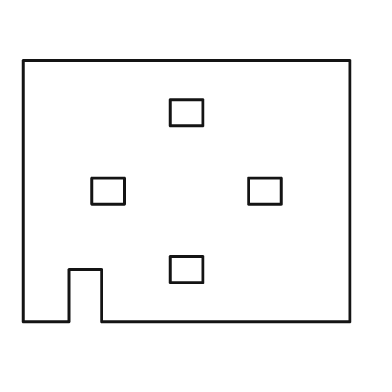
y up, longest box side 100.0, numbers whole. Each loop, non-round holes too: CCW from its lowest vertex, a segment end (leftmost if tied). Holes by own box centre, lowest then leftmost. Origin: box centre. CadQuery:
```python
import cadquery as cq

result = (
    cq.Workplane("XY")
    .moveTo(-50.0, -40.0)
    .lineTo(-36.0, -40.0)
    .lineTo(-36.0, -24.0)
    .lineTo(-26.0, -24.0)
    .lineTo(-26.0, -40.0)
    .lineTo(50.0, -40.0)
    .lineTo(50.0, 40.0)
    .lineTo(-50.0, 40.0)
    .close()
    .moveTo(-5.0, -28.0)
    .lineTo(5.0, -28.0)
    .lineTo(5.0, -20.0)
    .lineTo(-5.0, -20.0)
    .close()
    .moveTo(-29.0, -4.0)
    .lineTo(-19.0, -4.0)
    .lineTo(-19.0, 4.0)
    .lineTo(-29.0, 4.0)
    .close()
    .moveTo(19.0, -4.0)
    .lineTo(29.0, -4.0)
    .lineTo(29.0, 4.0)
    .lineTo(19.0, 4.0)
    .close()
    .moveTo(-5.0, 20.0)
    .lineTo(5.0, 20.0)
    .lineTo(5.0, 28.0)
    .lineTo(-5.0, 28.0)
    .close()
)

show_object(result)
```